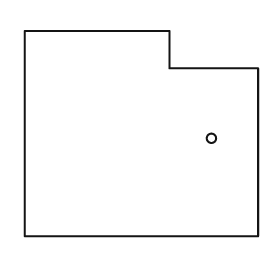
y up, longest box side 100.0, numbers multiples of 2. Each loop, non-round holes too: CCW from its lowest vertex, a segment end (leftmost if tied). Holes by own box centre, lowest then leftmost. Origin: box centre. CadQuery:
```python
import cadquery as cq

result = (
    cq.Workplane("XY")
    .moveTo(-50.0, -44.0)
    .lineTo(50.0, -44.0)
    .lineTo(50.0, 28.0)
    .lineTo(12.0, 28.0)
    .lineTo(12.0, 44.0)
    .lineTo(-50.0, 44.0)
    .close()
    .moveTo(30.0, -2.0)
    .circle(2.0)
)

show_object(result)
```